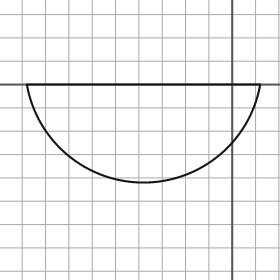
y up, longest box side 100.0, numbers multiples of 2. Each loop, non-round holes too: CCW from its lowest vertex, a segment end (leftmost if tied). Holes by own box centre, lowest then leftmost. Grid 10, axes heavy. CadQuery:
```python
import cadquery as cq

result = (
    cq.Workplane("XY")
    .moveTo(-88.0, 0.0)
    .threePointArc((-38.0, -42.0), (12.0, 0.0))
    .close()
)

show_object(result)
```